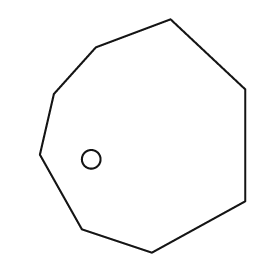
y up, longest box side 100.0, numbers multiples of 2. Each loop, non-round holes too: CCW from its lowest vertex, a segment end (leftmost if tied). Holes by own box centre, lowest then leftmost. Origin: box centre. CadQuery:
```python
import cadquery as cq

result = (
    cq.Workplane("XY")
    .moveTo(4.0, -50.0)
    .lineTo(44.0, -28.0)
    .lineTo(44.0, 20.0)
    .lineTo(12.0, 50.0)
    .lineTo(-20.0, 38.0)
    .lineTo(-38.0, 18.0)
    .lineTo(-44.0, -8.0)
    .lineTo(-26.0, -40.0)
    .close()
    .moveTo(-22.0, -10.0)
    .circle(4.0)
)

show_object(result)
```